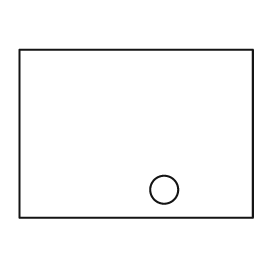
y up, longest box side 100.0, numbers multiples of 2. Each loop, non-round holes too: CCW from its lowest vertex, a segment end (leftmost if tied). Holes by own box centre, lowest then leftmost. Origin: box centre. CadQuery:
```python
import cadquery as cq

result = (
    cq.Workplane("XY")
    .moveTo(-50.0, -36.0)
    .lineTo(50.0, -36.0)
    .lineTo(50.0, 36.0)
    .lineTo(-50.0, 36.0)
    .close()
    .moveTo(12.0, -24.0)
    .circle(6.0)
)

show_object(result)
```